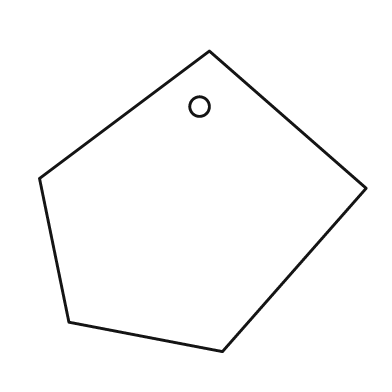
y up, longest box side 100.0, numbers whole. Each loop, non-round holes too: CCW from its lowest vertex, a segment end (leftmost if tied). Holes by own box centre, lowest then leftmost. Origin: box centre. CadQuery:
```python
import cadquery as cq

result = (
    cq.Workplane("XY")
    .moveTo(6.0, -46.0)
    .lineTo(50.0, 4.0)
    .lineTo(2.0, 46.0)
    .lineTo(-50.0, 7.0)
    .lineTo(-41.0, -37.0)
    .close()
    .moveTo(-1.0, 29.0)
    .circle(3.0)
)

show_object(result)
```